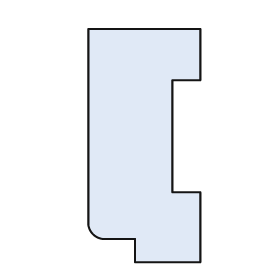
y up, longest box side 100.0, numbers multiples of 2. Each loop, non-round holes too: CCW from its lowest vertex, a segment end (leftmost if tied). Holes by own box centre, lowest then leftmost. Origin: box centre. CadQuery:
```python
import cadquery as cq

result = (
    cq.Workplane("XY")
    .moveTo(-4.0, -50.0)
    .lineTo(24.0, -50.0)
    .lineTo(24.0, -20.0)
    .lineTo(12.0, -20.0)
    .lineTo(12.0, 28.0)
    .lineTo(24.0, 28.0)
    .lineTo(24.0, 50.0)
    .lineTo(-24.0, 50.0)
    .lineTo(-24.0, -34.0)
    .threePointArc((-22.0, -38.0), (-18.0, -40.0))
    .lineTo(-4.0, -40.0)
    .close()
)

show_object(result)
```